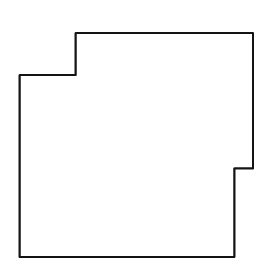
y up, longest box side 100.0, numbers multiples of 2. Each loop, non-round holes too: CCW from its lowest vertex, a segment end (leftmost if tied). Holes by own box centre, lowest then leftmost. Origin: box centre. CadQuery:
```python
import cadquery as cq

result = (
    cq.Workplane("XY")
    .moveTo(-50.0, -48.0)
    .lineTo(42.0, -48.0)
    .lineTo(42.0, -10.0)
    .lineTo(50.0, -10.0)
    .lineTo(50.0, 48.0)
    .lineTo(-26.0, 48.0)
    .lineTo(-26.0, 30.0)
    .lineTo(-50.0, 30.0)
    .close()
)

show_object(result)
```